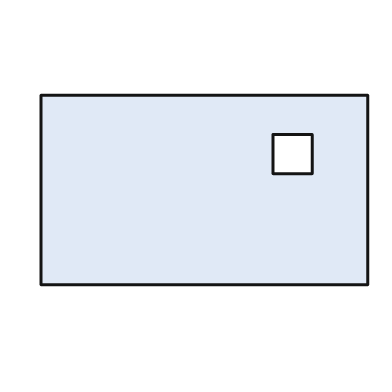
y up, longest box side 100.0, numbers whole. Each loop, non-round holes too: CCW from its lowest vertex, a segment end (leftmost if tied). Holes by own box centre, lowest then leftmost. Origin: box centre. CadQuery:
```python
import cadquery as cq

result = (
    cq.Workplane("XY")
    .moveTo(-50.0, -29.0)
    .lineTo(50.0, -29.0)
    .lineTo(50.0, 29.0)
    .lineTo(-50.0, 29.0)
    .close()
    .moveTo(21.0, 5.0)
    .lineTo(33.0, 5.0)
    .lineTo(33.0, 17.0)
    .lineTo(21.0, 17.0)
    .close()
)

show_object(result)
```